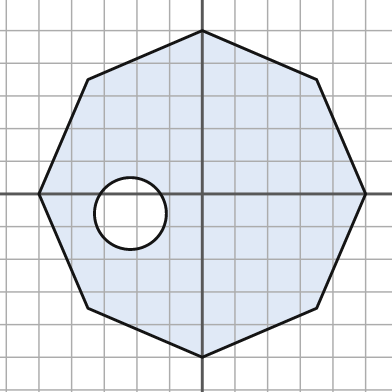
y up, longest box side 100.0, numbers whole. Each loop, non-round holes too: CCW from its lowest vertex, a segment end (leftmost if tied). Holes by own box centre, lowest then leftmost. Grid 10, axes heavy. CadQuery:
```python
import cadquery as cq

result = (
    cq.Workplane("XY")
    .moveTo(0.0, -50.0)
    .lineTo(35.0, -35.0)
    .lineTo(50.0, 0.0)
    .lineTo(35.0, 35.0)
    .lineTo(0.0, 50.0)
    .lineTo(-35.0, 35.0)
    .lineTo(-50.0, 0.0)
    .lineTo(-35.0, -35.0)
    .close()
    .moveTo(-22.0, -6.0)
    .circle(11.0)
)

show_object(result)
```